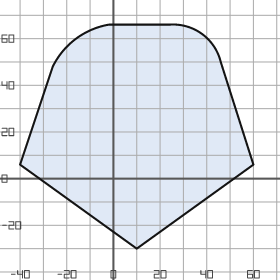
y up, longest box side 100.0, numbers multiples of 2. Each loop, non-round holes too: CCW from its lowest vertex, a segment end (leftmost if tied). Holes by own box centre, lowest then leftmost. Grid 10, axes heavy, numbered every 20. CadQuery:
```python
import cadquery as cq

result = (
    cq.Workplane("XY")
    .moveTo(10.0, -30.0)
    .lineTo(60.0, 6.0)
    .lineTo(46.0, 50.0)
    .threePointArc((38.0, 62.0), (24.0, 66.0))
    .lineTo(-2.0, 66.0)
    .threePointArc((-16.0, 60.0), (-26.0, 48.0))
    .lineTo(-40.0, 6.0)
    .close()
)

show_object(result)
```